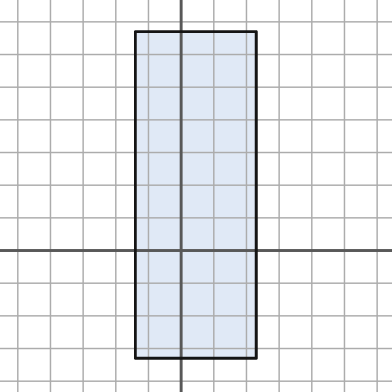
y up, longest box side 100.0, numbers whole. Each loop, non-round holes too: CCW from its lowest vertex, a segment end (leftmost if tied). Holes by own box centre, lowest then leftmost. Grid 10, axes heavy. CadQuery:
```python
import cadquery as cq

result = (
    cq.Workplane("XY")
    .moveTo(-14.0, -33.0)
    .lineTo(23.0, -33.0)
    .lineTo(23.0, 67.0)
    .lineTo(-14.0, 67.0)
    .close()
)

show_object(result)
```